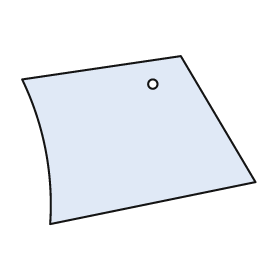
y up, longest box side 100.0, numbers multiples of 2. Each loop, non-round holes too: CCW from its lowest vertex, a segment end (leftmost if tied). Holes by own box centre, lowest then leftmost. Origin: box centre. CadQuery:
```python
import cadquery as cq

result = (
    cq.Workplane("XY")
    .moveTo(-38.0, -36.0)
    .lineTo(50.0, -18.0)
    .lineTo(18.0, 36.0)
    .lineTo(-50.0, 26.0)
    .threePointArc((-40.0, -4.0), (-38.0, -36.0))
    .close()
    .moveTo(6.0, 24.0)
    .circle(2.0)
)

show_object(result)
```